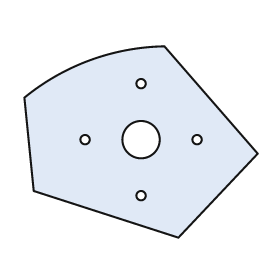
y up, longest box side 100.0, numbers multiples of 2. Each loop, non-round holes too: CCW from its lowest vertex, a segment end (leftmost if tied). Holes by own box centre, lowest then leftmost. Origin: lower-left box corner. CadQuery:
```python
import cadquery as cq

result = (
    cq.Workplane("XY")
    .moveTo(66.0, 0.0)
    .lineTo(100.0, 36.0)
    .lineTo(60.0, 82.0)
    .threePointArc((28.0, 76.0), (0.0, 60.0))
    .lineTo(4.0, 20.0)
    .close()
    .moveTo(50.0, 18.0)
    .circle(2.0)
    .moveTo(26.0, 42.0)
    .circle(2.0)
    .moveTo(50.0, 42.0)
    .circle(8.0)
    .moveTo(74.0, 42.0)
    .circle(2.0)
    .moveTo(50.0, 66.0)
    .circle(2.0)
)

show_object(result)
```